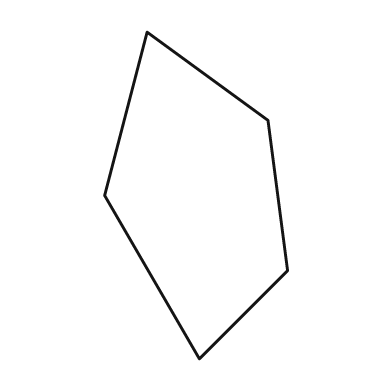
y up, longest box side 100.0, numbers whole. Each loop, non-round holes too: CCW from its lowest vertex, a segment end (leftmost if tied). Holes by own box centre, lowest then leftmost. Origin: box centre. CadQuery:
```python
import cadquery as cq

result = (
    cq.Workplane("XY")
    .moveTo(1.0, -50.0)
    .lineTo(28.0, -23.0)
    .lineTo(22.0, 23.0)
    .lineTo(-15.0, 50.0)
    .lineTo(-28.0, 0.0)
    .close()
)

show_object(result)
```